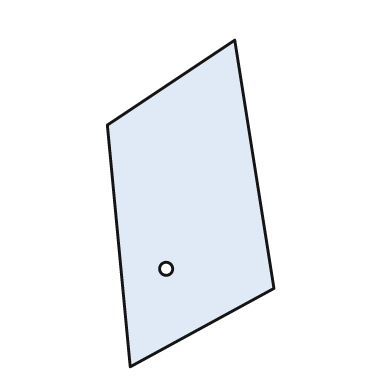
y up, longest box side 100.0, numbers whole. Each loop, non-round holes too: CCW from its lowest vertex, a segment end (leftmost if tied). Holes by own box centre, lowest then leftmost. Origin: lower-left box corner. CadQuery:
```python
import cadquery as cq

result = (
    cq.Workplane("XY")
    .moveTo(7.0, 0.0)
    .lineTo(51.0, 24.0)
    .lineTo(39.0, 100.0)
    .lineTo(0.0, 74.0)
    .close()
    .moveTo(18.0, 30.0)
    .circle(2.0)
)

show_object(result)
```